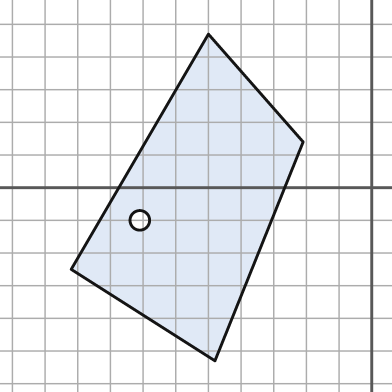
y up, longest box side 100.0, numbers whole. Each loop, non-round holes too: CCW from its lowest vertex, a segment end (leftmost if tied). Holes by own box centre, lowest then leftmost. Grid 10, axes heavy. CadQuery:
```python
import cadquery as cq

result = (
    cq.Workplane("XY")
    .moveTo(-48.0, -53.0)
    .lineTo(-21.0, 14.0)
    .lineTo(-50.0, 47.0)
    .lineTo(-92.0, -25.0)
    .close()
    .moveTo(-71.0, -10.0)
    .circle(3.0)
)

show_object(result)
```